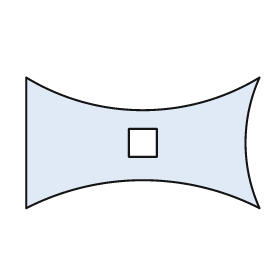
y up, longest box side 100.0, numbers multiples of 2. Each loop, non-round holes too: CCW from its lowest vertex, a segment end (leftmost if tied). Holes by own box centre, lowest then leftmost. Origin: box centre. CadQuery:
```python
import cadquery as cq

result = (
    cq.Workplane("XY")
    .moveTo(-50.0, -28.0)
    .threePointArc((0.0, -16.0), (50.0, -28.0))
    .threePointArc((44.0, 0.0), (50.0, 28.0))
    .threePointArc((0.0, 14.0), (-50.0, 28.0))
    .close()
    .moveTo(-6.0, -6.0)
    .lineTo(6.0, -6.0)
    .lineTo(6.0, 6.0)
    .lineTo(-6.0, 6.0)
    .close()
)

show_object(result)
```